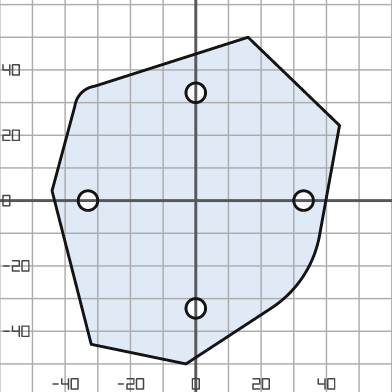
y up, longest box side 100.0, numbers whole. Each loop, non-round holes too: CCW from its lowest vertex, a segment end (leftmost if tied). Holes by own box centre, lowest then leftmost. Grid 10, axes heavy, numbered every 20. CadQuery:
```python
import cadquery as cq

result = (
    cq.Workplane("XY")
    .moveTo(-3.0, -50.0)
    .lineTo(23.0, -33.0)
    .threePointArc((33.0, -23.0), (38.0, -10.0))
    .lineTo(44.0, 23.0)
    .lineTo(16.0, 50.0)
    .lineTo(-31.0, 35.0)
    .threePointArc((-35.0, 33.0), (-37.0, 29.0))
    .lineTo(-44.0, 3.0)
    .lineTo(-32.0, -44.0)
    .close()
    .moveTo(0.0, -33.0)
    .circle(3.0)
    .moveTo(-33.0, 0.0)
    .circle(3.0)
    .moveTo(33.0, 0.0)
    .circle(3.0)
    .moveTo(0.0, 33.0)
    .circle(3.0)
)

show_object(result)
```